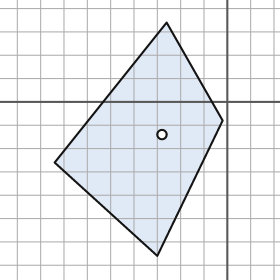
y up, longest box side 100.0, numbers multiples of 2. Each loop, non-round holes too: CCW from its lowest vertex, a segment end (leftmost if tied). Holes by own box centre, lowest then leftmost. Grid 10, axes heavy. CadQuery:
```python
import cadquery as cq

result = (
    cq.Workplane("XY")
    .moveTo(-30.0, -66.0)
    .lineTo(-2.0, -8.0)
    .lineTo(-26.0, 34.0)
    .lineTo(-74.0, -26.0)
    .close()
    .moveTo(-28.0, -14.0)
    .circle(2.0)
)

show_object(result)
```